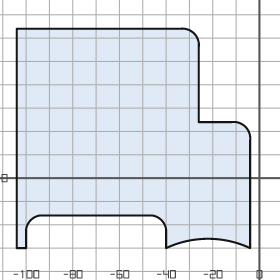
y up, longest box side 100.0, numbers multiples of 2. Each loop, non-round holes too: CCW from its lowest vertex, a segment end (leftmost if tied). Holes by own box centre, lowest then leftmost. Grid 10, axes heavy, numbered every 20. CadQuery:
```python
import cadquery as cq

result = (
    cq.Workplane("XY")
    .moveTo(-104.0, -30.0)
    .lineTo(-100.0, -30.0)
    .lineTo(-100.0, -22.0)
    .threePointArc((-98.0, -18.0), (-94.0, -16.0))
    .lineTo(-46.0, -16.0)
    .threePointArc((-42.0, -18.0), (-40.0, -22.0))
    .lineTo(-40.0, -30.0)
    .threePointArc((-22.0, -26.0), (-4.0, -30.0))
    .lineTo(-4.0, 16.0)
    .threePointArc((-6.0, 22.0), (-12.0, 24.0))
    .lineTo(-26.0, 24.0)
    .lineTo(-26.0, 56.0)
    .threePointArc((-28.0, 62.0), (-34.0, 64.0))
    .lineTo(-104.0, 64.0)
    .close()
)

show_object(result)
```